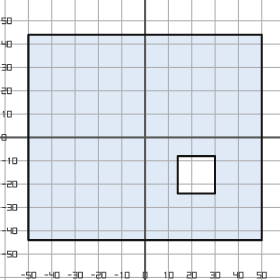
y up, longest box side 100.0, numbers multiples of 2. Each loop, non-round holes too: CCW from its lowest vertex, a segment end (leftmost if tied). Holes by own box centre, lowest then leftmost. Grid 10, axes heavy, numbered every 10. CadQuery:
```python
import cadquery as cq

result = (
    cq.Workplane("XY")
    .moveTo(-50.0, -44.0)
    .lineTo(50.0, -44.0)
    .lineTo(50.0, 44.0)
    .lineTo(-50.0, 44.0)
    .close()
    .moveTo(14.0, -24.0)
    .lineTo(30.0, -24.0)
    .lineTo(30.0, -8.0)
    .lineTo(14.0, -8.0)
    .close()
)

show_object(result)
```